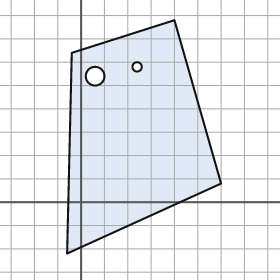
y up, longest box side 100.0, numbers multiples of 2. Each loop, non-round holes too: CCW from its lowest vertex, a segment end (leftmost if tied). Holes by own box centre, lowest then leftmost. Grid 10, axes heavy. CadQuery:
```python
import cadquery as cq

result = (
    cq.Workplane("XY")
    .moveTo(-6.0, -22.0)
    .lineTo(60.0, 8.0)
    .lineTo(40.0, 78.0)
    .lineTo(-4.0, 64.0)
    .close()
    .moveTo(6.0, 54.0)
    .circle(4.0)
    .moveTo(24.0, 58.0)
    .circle(2.0)
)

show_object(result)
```